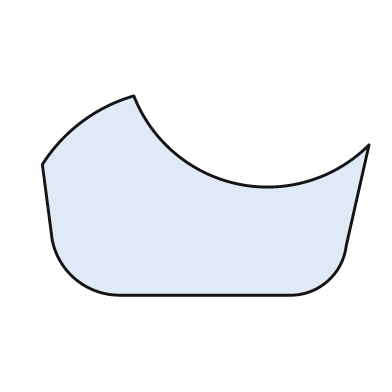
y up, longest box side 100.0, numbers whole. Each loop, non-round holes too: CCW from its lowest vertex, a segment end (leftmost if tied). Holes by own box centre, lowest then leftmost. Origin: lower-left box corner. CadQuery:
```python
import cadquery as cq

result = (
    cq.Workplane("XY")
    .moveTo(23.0, 0.0)
    .lineTo(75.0, 0.0)
    .threePointArc((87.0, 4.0), (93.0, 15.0))
    .lineTo(100.0, 46.0)
    .threePointArc((60.0, 34.0), (28.0, 61.0))
    .threePointArc((12.0, 53.0), (0.0, 40.0))
    .lineTo(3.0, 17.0)
    .threePointArc((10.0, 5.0), (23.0, 0.0))
    .close()
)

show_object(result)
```